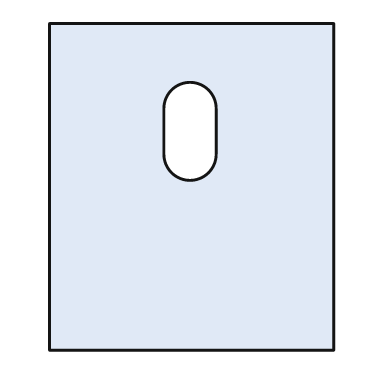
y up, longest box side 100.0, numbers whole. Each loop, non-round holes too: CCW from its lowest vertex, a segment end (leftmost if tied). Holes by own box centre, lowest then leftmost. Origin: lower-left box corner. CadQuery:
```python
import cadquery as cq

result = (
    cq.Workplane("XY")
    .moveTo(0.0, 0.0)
    .lineTo(87.0, 0.0)
    .lineTo(87.0, 100.0)
    .lineTo(0.0, 100.0)
    .close()
    .moveTo(35.0, 60.0)
    .threePointArc((43.0, 52.0), (51.0, 60.0))
    .lineTo(51.0, 74.0)
    .threePointArc((43.0, 82.0), (35.0, 74.0))
    .close()
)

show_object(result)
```